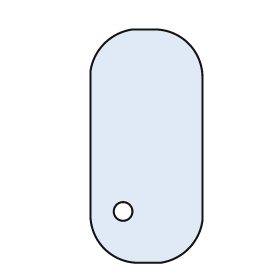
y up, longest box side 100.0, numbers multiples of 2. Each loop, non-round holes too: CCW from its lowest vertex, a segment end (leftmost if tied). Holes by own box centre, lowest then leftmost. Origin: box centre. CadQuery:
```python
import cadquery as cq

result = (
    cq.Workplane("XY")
    .moveTo(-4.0, -50.0)
    .lineTo(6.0, -50.0)
    .threePointArc((18.0, -44.0), (24.0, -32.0))
    .lineTo(24.0, 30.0)
    .threePointArc((18.0, 44.0), (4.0, 50.0))
    .lineTo(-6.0, 50.0)
    .threePointArc((-18.0, 44.0), (-24.0, 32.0))
    .lineTo(-24.0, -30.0)
    .threePointArc((-18.0, -44.0), (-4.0, -50.0))
    .close()
    .moveTo(-10.0, -28.0)
    .circle(4.0)
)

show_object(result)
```